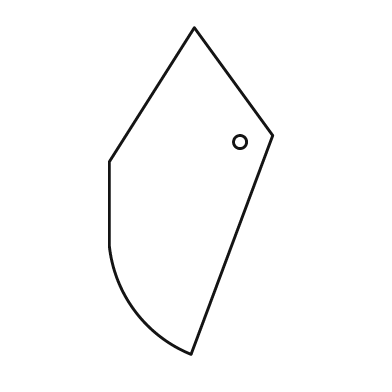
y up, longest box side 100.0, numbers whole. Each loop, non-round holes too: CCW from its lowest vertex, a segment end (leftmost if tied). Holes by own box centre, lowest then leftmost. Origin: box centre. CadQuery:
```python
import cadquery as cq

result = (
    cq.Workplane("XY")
    .moveTo(0.0, -50.0)
    .lineTo(25.0, 17.0)
    .lineTo(1.0, 50.0)
    .lineTo(-25.0, 9.0)
    .lineTo(-25.0, -17.0)
    .threePointArc((-17.0, -37.0), (0.0, -50.0))
    .close()
    .moveTo(15.0, 15.0)
    .circle(2.0)
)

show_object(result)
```